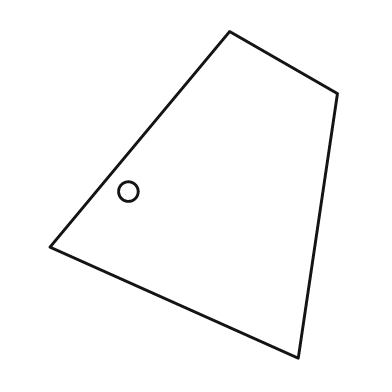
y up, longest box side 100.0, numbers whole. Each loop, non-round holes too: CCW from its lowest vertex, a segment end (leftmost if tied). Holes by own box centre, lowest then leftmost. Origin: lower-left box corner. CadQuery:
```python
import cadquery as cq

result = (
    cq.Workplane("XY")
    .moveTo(76.0, 0.0)
    .lineTo(88.0, 81.0)
    .lineTo(55.0, 100.0)
    .lineTo(0.0, 34.0)
    .close()
    .moveTo(24.0, 51.0)
    .circle(3.0)
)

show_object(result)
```